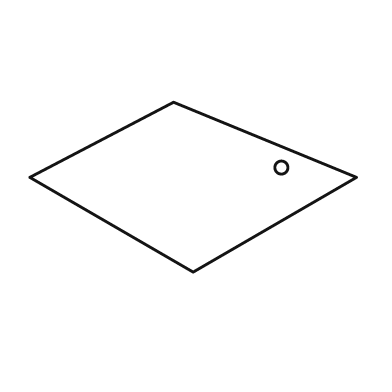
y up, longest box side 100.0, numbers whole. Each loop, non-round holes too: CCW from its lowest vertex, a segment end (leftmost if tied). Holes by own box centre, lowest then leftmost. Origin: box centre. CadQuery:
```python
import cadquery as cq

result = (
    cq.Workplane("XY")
    .moveTo(0.0, -26.0)
    .lineTo(50.0, 3.0)
    .lineTo(-6.0, 26.0)
    .lineTo(-50.0, 3.0)
    .close()
    .moveTo(27.0, 6.0)
    .circle(2.0)
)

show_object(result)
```